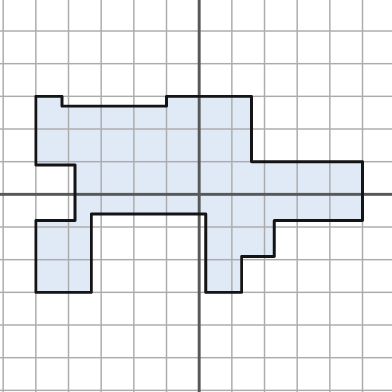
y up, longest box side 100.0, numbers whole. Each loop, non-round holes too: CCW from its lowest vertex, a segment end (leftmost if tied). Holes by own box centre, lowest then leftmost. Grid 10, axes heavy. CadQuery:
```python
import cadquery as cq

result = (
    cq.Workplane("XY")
    .moveTo(-50.0, -30.0)
    .lineTo(-33.0, -30.0)
    .lineTo(-33.0, -6.0)
    .lineTo(2.0, -6.0)
    .lineTo(2.0, -30.0)
    .lineTo(13.0, -30.0)
    .lineTo(13.0, -19.0)
    .lineTo(23.0, -19.0)
    .lineTo(23.0, -8.0)
    .lineTo(50.0, -8.0)
    .lineTo(50.0, 10.0)
    .lineTo(16.0, 10.0)
    .lineTo(16.0, 30.0)
    .lineTo(-10.0, 30.0)
    .lineTo(-10.0, 27.0)
    .lineTo(-42.0, 27.0)
    .lineTo(-42.0, 30.0)
    .lineTo(-50.0, 30.0)
    .lineTo(-50.0, 9.0)
    .lineTo(-38.0, 9.0)
    .lineTo(-38.0, -8.0)
    .lineTo(-50.0, -8.0)
    .close()
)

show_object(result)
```